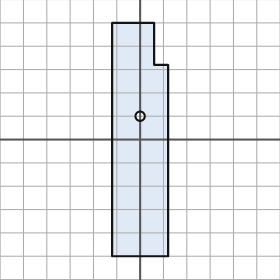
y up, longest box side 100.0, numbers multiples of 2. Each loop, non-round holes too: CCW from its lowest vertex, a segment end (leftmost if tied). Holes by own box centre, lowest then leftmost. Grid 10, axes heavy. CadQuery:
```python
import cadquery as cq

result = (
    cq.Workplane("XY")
    .moveTo(-12.0, -50.0)
    .lineTo(12.0, -50.0)
    .lineTo(12.0, 32.0)
    .lineTo(6.0, 32.0)
    .lineTo(6.0, 50.0)
    .lineTo(-12.0, 50.0)
    .close()
    .moveTo(0.0, 10.0)
    .circle(2.0)
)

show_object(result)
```